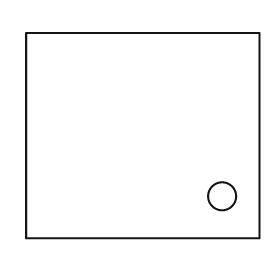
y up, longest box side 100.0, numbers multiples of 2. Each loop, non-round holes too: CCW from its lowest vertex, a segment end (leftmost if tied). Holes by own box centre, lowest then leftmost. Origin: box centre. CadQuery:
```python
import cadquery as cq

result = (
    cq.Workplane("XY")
    .moveTo(-50.0, -44.0)
    .lineTo(50.0, -44.0)
    .lineTo(50.0, 44.0)
    .lineTo(-50.0, 44.0)
    .close()
    .moveTo(34.0, -26.0)
    .circle(6.0)
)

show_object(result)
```